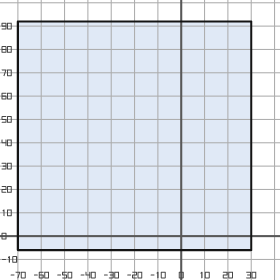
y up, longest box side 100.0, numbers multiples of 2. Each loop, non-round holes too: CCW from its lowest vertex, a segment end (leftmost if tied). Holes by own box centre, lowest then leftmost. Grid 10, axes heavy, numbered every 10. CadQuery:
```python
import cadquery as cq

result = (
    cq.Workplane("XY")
    .moveTo(-70.0, -6.0)
    .lineTo(30.0, -6.0)
    .lineTo(30.0, 92.0)
    .lineTo(-70.0, 92.0)
    .close()
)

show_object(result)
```